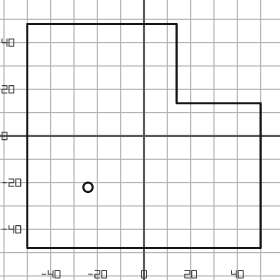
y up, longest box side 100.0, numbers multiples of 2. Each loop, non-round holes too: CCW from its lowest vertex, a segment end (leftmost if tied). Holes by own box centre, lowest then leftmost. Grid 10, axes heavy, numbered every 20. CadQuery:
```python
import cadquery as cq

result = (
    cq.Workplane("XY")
    .moveTo(-50.0, -48.0)
    .lineTo(50.0, -48.0)
    .lineTo(50.0, 14.0)
    .lineTo(14.0, 14.0)
    .lineTo(14.0, 48.0)
    .lineTo(-50.0, 48.0)
    .close()
    .moveTo(-24.0, -22.0)
    .circle(2.0)
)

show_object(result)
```